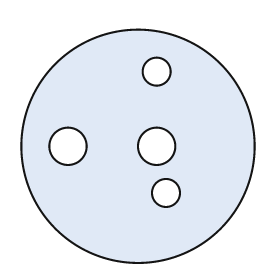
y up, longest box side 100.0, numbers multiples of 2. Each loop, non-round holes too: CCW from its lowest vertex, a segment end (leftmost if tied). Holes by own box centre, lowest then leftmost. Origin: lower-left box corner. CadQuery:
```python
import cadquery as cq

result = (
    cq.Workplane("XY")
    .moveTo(50.0, 50.0)
    .circle(50.0)
    .moveTo(62.0, 30.0)
    .circle(6.0)
    .moveTo(20.0, 50.0)
    .circle(8.0)
    .moveTo(58.0, 50.0)
    .circle(8.0)
    .moveTo(58.0, 82.0)
    .circle(6.0)
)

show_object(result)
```